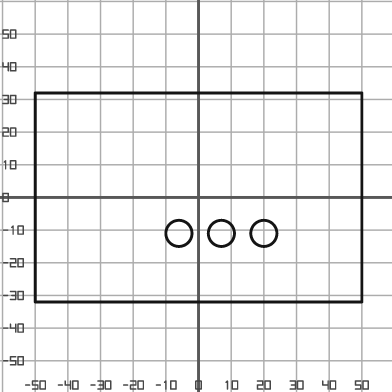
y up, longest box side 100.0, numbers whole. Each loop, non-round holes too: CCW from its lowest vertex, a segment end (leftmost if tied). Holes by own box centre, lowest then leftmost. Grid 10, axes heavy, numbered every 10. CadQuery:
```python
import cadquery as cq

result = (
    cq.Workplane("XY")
    .moveTo(-50.0, -32.0)
    .lineTo(50.0, -32.0)
    .lineTo(50.0, 32.0)
    .lineTo(-50.0, 32.0)
    .close()
    .moveTo(-6.0, -11.0)
    .circle(4.0)
    .moveTo(7.0, -11.0)
    .circle(4.0)
    .moveTo(20.0, -11.0)
    .circle(4.0)
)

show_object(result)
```